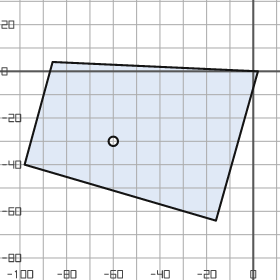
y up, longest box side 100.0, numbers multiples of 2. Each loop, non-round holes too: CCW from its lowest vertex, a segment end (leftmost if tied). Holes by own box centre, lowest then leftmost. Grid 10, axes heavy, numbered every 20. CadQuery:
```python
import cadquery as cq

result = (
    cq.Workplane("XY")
    .moveTo(-16.0, -64.0)
    .lineTo(2.0, 0.0)
    .lineTo(-86.0, 4.0)
    .lineTo(-98.0, -40.0)
    .close()
    .moveTo(-60.0, -30.0)
    .circle(2.0)
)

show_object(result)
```